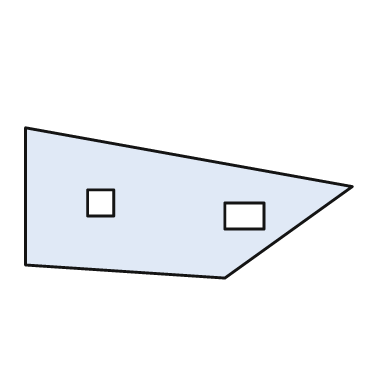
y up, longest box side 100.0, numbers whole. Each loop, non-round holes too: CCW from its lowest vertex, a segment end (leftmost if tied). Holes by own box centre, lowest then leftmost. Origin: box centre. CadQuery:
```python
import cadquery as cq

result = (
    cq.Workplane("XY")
    .moveTo(11.0, -23.0)
    .lineTo(50.0, 5.0)
    .lineTo(-50.0, 23.0)
    .lineTo(-50.0, -19.0)
    .close()
    .moveTo(11.0, -8.0)
    .lineTo(23.0, -8.0)
    .lineTo(23.0, 0.0)
    .lineTo(11.0, 0.0)
    .close()
    .moveTo(-31.0, -4.0)
    .lineTo(-23.0, -4.0)
    .lineTo(-23.0, 4.0)
    .lineTo(-31.0, 4.0)
    .close()
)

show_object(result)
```